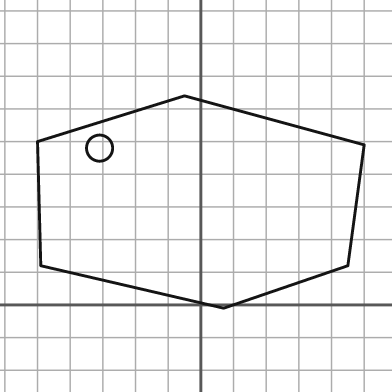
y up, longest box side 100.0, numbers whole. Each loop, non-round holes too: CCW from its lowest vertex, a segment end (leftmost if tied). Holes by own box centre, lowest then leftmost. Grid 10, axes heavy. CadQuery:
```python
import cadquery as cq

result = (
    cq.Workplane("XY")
    .moveTo(7.0, -1.0)
    .lineTo(45.0, 12.0)
    .lineTo(50.0, 49.0)
    .lineTo(-5.0, 64.0)
    .lineTo(-50.0, 50.0)
    .lineTo(-49.0, 12.0)
    .close()
    .moveTo(-31.0, 48.0)
    .circle(4.0)
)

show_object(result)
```